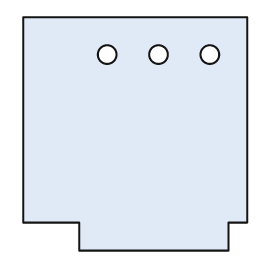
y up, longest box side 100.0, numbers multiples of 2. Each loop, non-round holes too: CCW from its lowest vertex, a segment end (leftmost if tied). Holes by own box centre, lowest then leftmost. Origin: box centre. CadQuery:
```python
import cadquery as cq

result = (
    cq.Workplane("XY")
    .moveTo(-24.0, -50.0)
    .lineTo(40.0, -50.0)
    .lineTo(40.0, -38.0)
    .lineTo(48.0, -38.0)
    .lineTo(48.0, 50.0)
    .lineTo(-48.0, 50.0)
    .lineTo(-48.0, -38.0)
    .lineTo(-24.0, -38.0)
    .close()
    .moveTo(-12.0, 34.0)
    .circle(4.0)
    .moveTo(10.0, 34.0)
    .circle(4.0)
    .moveTo(32.0, 34.0)
    .circle(4.0)
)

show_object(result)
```